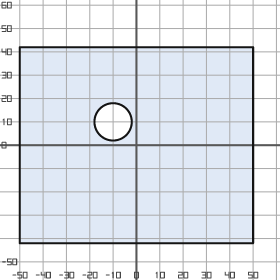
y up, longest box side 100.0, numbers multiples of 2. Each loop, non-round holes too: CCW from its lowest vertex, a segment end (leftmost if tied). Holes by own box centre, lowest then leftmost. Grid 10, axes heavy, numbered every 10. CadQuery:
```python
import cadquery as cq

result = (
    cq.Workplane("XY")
    .moveTo(-50.0, -42.0)
    .lineTo(50.0, -42.0)
    .lineTo(50.0, 42.0)
    .lineTo(-50.0, 42.0)
    .close()
    .moveTo(-10.0, 10.0)
    .circle(8.0)
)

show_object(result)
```